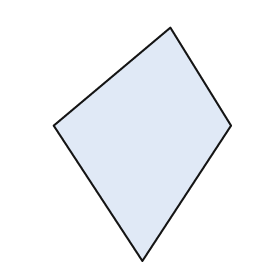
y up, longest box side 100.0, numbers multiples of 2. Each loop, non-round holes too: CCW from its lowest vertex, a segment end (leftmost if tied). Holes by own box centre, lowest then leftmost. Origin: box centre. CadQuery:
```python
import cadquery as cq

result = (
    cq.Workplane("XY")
    .moveTo(0.0, -50.0)
    .lineTo(38.0, 8.0)
    .lineTo(12.0, 50.0)
    .lineTo(-38.0, 8.0)
    .close()
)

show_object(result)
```